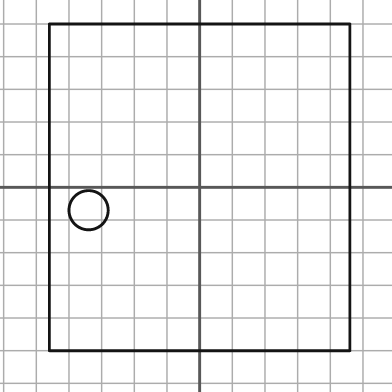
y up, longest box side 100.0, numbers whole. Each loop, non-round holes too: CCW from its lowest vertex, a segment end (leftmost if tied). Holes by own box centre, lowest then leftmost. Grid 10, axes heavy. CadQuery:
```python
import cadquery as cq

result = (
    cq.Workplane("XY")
    .moveTo(-46.0, -50.0)
    .lineTo(46.0, -50.0)
    .lineTo(46.0, 50.0)
    .lineTo(-46.0, 50.0)
    .close()
    .moveTo(-34.0, -7.0)
    .circle(6.0)
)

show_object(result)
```